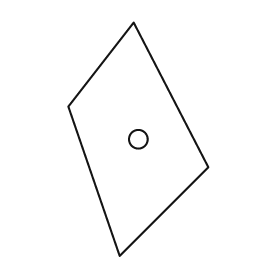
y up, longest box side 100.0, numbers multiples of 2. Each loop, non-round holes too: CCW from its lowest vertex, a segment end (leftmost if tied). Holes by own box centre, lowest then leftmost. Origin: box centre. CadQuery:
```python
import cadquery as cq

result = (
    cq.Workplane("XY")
    .moveTo(-8.0, -50.0)
    .lineTo(30.0, -12.0)
    .lineTo(-2.0, 50.0)
    .lineTo(-30.0, 14.0)
    .close()
    .moveTo(0.0, 0.0)
    .circle(4.0)
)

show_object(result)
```